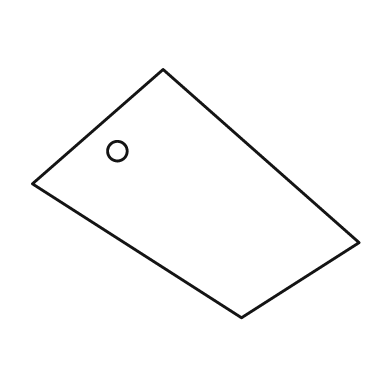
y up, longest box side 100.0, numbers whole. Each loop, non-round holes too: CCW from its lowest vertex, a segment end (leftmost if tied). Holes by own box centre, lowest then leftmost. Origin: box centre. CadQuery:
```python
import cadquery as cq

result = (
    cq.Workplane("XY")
    .moveTo(14.0, -38.0)
    .lineTo(50.0, -15.0)
    .lineTo(-10.0, 38.0)
    .lineTo(-50.0, 3.0)
    .close()
    .moveTo(-24.0, 13.0)
    .circle(3.0)
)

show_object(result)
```